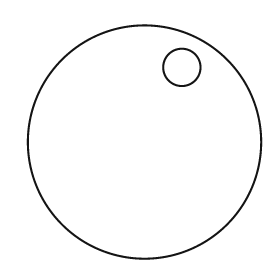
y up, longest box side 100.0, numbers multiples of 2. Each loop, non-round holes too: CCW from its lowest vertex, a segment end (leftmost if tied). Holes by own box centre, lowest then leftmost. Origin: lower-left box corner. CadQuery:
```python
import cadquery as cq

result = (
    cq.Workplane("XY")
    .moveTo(50.0, 50.0)
    .circle(50.0)
    .moveTo(66.0, 82.0)
    .circle(8.0)
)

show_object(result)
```